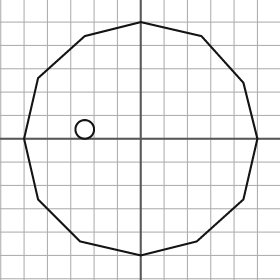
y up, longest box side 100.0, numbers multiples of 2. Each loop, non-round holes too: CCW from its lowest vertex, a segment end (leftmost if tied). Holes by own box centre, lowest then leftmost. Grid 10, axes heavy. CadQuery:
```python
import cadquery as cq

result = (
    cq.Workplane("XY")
    .moveTo(0.0, -50.0)
    .lineTo(24.0, -44.0)
    .lineTo(44.0, -26.0)
    .lineTo(50.0, 0.0)
    .lineTo(44.0, 24.0)
    .lineTo(26.0, 44.0)
    .lineTo(0.0, 50.0)
    .lineTo(-24.0, 44.0)
    .lineTo(-44.0, 26.0)
    .lineTo(-50.0, 0.0)
    .lineTo(-44.0, -26.0)
    .lineTo(-26.0, -44.0)
    .close()
    .moveTo(-24.0, 4.0)
    .circle(4.0)
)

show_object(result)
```